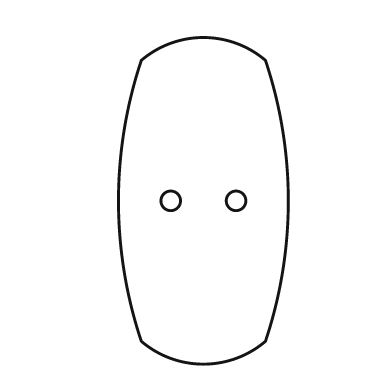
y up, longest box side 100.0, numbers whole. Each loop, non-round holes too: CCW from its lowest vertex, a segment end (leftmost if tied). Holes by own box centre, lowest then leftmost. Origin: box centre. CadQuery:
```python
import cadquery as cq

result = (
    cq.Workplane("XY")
    .moveTo(-19.0, -43.0)
    .threePointArc((0.0, -50.0), (19.0, -43.0))
    .threePointArc((26.0, 0.0), (19.0, 43.0))
    .threePointArc((0.0, 50.0), (-19.0, 43.0))
    .threePointArc((-26.0, 0.0), (-19.0, -43.0))
    .close()
    .moveTo(-10.0, 0.0)
    .circle(3.0)
    .moveTo(10.0, 0.0)
    .circle(3.0)
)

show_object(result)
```